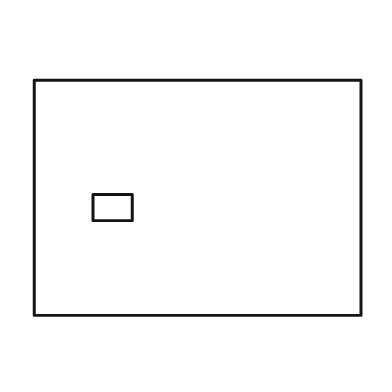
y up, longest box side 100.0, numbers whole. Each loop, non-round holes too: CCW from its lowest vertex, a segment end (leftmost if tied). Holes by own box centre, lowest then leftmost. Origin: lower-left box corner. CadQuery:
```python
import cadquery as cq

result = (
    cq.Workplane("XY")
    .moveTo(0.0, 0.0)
    .lineTo(100.0, 0.0)
    .lineTo(100.0, 72.0)
    .lineTo(0.0, 72.0)
    .close()
    .moveTo(18.0, 29.0)
    .lineTo(30.0, 29.0)
    .lineTo(30.0, 37.0)
    .lineTo(18.0, 37.0)
    .close()
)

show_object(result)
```